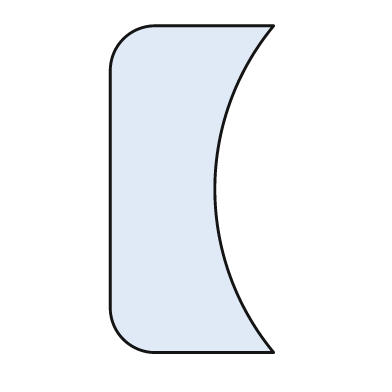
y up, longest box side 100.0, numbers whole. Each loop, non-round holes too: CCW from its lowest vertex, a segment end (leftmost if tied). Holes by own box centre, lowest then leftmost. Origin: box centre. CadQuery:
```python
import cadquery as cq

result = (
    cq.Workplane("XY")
    .moveTo(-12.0, -50.0)
    .lineTo(25.0, -50.0)
    .threePointArc((7.0, 0.0), (25.0, 50.0))
    .lineTo(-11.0, 50.0)
    .threePointArc((-21.0, 46.0), (-25.0, 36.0))
    .lineTo(-25.0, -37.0)
    .threePointArc((-21.0, -46.0), (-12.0, -50.0))
    .close()
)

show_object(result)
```